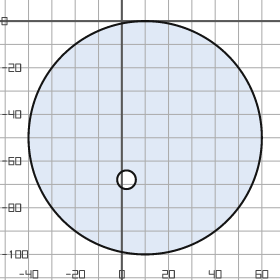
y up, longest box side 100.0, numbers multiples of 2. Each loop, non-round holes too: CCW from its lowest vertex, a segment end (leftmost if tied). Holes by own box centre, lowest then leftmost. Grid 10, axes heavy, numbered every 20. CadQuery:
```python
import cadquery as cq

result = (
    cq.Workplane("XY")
    .moveTo(10.0, -50.0)
    .circle(50.0)
    .moveTo(2.0, -68.0)
    .circle(4.0)
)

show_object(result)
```